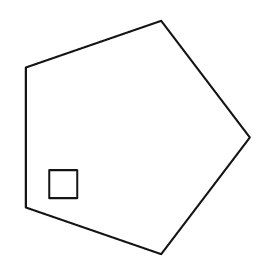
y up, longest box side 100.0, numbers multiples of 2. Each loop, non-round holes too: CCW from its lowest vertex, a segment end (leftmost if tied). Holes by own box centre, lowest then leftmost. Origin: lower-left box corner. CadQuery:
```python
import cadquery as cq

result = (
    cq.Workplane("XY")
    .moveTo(58.0, 0.0)
    .lineTo(96.0, 50.0)
    .lineTo(58.0, 100.0)
    .lineTo(0.0, 80.0)
    .lineTo(0.0, 20.0)
    .close()
    .moveTo(10.0, 24.0)
    .lineTo(22.0, 24.0)
    .lineTo(22.0, 36.0)
    .lineTo(10.0, 36.0)
    .close()
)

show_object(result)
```